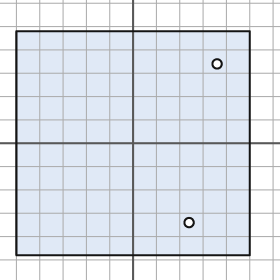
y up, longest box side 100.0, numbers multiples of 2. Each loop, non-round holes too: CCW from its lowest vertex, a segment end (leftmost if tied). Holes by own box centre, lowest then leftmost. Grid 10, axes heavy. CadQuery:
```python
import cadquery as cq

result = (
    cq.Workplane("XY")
    .moveTo(-50.0, -48.0)
    .lineTo(50.0, -48.0)
    .lineTo(50.0, 48.0)
    .lineTo(-50.0, 48.0)
    .close()
    .moveTo(24.0, -34.0)
    .circle(2.0)
    .moveTo(36.0, 34.0)
    .circle(2.0)
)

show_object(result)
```